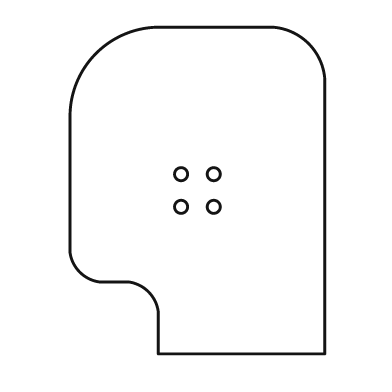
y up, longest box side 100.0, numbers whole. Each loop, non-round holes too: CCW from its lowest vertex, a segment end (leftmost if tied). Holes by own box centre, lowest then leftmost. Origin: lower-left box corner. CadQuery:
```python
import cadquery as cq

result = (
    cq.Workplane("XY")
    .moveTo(27.0, 0.0)
    .lineTo(78.0, 0.0)
    .lineTo(78.0, 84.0)
    .threePointArc((73.0, 95.0), (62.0, 100.0))
    .lineTo(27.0, 100.0)
    .threePointArc((8.0, 92.0), (0.0, 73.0))
    .lineTo(0.0, 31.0)
    .threePointArc((3.0, 25.0), (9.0, 22.0))
    .lineTo(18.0, 22.0)
    .threePointArc((24.0, 19.0), (27.0, 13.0))
    .close()
    .moveTo(34.0, 45.0)
    .circle(2.0)
    .moveTo(44.0, 45.0)
    .circle(2.0)
    .moveTo(34.0, 55.0)
    .circle(2.0)
    .moveTo(44.0, 55.0)
    .circle(2.0)
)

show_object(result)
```